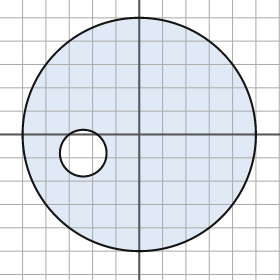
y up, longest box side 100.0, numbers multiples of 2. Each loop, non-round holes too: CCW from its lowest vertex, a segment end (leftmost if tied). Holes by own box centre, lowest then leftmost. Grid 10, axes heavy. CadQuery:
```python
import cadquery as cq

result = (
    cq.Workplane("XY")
    .moveTo(0.0, 0.0)
    .circle(50.0)
    .moveTo(-24.0, -8.0)
    .circle(10.0)
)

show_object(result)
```